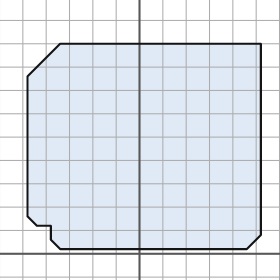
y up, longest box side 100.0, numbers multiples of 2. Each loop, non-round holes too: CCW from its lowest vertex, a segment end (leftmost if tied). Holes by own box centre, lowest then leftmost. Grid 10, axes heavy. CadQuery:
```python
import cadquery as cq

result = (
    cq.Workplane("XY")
    .moveTo(-34.0, 2.0)
    .lineTo(46.0, 2.0)
    .lineTo(52.0, 8.0)
    .lineTo(52.0, 90.0)
    .lineTo(-34.0, 90.0)
    .lineTo(-48.0, 76.0)
    .lineTo(-48.0, 16.0)
    .lineTo(-44.0, 12.0)
    .lineTo(-38.0, 12.0)
    .lineTo(-38.0, 6.0)
    .close()
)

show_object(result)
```